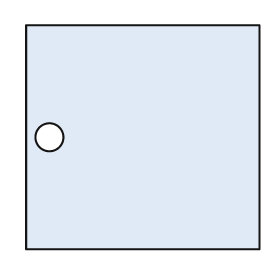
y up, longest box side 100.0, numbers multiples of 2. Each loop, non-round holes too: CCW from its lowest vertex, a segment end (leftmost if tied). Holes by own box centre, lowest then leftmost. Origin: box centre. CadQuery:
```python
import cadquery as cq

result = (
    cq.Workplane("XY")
    .moveTo(-50.0, -48.0)
    .lineTo(50.0, -48.0)
    .lineTo(50.0, 48.0)
    .lineTo(-50.0, 48.0)
    .close()
    .moveTo(-40.0, 0.0)
    .circle(6.0)
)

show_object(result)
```